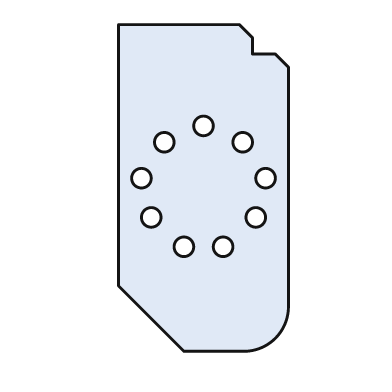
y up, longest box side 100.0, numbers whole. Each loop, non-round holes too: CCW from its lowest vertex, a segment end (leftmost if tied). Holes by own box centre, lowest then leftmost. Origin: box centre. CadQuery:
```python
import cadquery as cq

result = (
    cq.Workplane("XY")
    .moveTo(-6.0, -50.0)
    .lineTo(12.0, -50.0)
    .threePointArc((22.0, -46.0), (26.0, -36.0))
    .lineTo(26.0, 37.0)
    .lineTo(22.0, 41.0)
    .lineTo(15.0, 41.0)
    .lineTo(15.0, 46.0)
    .lineTo(11.0, 50.0)
    .lineTo(-26.0, 50.0)
    .lineTo(-26.0, -30.0)
    .close()
    .moveTo(-6.0, -18.0)
    .circle(3.0)
    .moveTo(6.0, -18.0)
    .circle(3.0)
    .moveTo(-16.0, -9.0)
    .circle(3.0)
    .moveTo(16.0, -9.0)
    .circle(3.0)
    .moveTo(-19.0, 3.0)
    .circle(3.0)
    .moveTo(19.0, 3.0)
    .circle(3.0)
    .moveTo(-12.0, 14.0)
    .circle(3.0)
    .moveTo(12.0, 14.0)
    .circle(3.0)
    .moveTo(0.0, 19.0)
    .circle(3.0)
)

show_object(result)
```